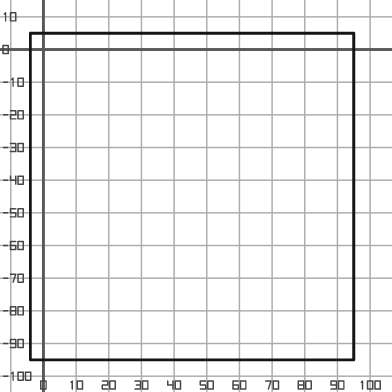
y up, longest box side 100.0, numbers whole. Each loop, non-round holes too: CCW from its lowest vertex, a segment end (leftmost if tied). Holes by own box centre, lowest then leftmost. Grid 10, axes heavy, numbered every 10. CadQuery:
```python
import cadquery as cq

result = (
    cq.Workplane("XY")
    .moveTo(-4.0, -95.0)
    .lineTo(95.0, -95.0)
    .lineTo(95.0, 5.0)
    .lineTo(-4.0, 5.0)
    .close()
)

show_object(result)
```